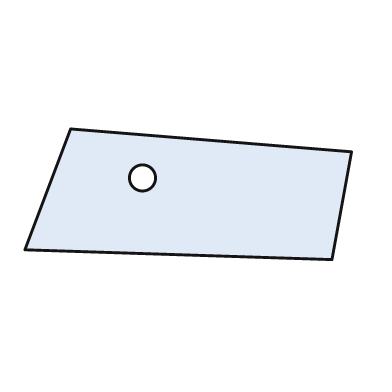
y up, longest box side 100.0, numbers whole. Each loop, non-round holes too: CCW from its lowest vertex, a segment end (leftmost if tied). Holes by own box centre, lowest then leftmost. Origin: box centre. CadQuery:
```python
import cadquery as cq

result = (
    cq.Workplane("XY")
    .moveTo(44.0, -20.0)
    .lineTo(50.0, 13.0)
    .lineTo(-36.0, 20.0)
    .lineTo(-50.0, -17.0)
    .close()
    .moveTo(-14.0, 5.0)
    .circle(4.0)
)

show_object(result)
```